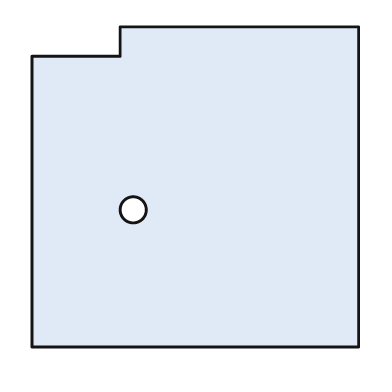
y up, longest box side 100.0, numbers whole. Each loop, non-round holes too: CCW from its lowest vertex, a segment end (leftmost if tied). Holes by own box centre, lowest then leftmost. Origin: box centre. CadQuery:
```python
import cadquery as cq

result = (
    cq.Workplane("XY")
    .moveTo(-50.0, -49.0)
    .lineTo(50.0, -49.0)
    .lineTo(50.0, 49.0)
    .lineTo(-23.0, 49.0)
    .lineTo(-23.0, 40.0)
    .lineTo(-50.0, 40.0)
    .close()
    .moveTo(-19.0, -7.0)
    .circle(4.0)
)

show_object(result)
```